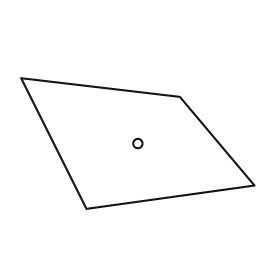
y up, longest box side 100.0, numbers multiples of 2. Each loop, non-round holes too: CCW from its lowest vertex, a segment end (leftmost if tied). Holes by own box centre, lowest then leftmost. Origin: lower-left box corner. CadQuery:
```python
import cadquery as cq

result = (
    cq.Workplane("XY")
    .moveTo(28.0, 0.0)
    .lineTo(100.0, 10.0)
    .lineTo(68.0, 48.0)
    .lineTo(0.0, 56.0)
    .close()
    .moveTo(50.0, 28.0)
    .circle(2.0)
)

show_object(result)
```